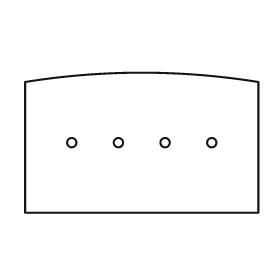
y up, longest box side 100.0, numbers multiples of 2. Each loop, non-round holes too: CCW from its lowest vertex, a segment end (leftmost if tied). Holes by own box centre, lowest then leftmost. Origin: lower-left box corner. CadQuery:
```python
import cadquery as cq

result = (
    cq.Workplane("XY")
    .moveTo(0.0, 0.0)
    .lineTo(100.0, 0.0)
    .lineTo(100.0, 56.0)
    .threePointArc((50.0, 60.0), (0.0, 56.0))
    .close()
    .moveTo(20.0, 30.0)
    .circle(2.0)
    .moveTo(40.0, 30.0)
    .circle(2.0)
    .moveTo(60.0, 30.0)
    .circle(2.0)
    .moveTo(80.0, 30.0)
    .circle(2.0)
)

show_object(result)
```